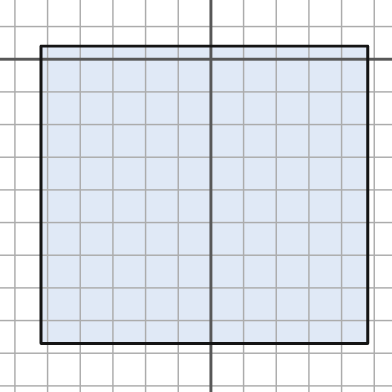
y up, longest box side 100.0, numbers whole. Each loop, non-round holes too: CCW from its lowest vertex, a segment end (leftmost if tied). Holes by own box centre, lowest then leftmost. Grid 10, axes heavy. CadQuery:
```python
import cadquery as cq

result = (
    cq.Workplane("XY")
    .moveTo(-52.0, -87.0)
    .lineTo(48.0, -87.0)
    .lineTo(48.0, 4.0)
    .lineTo(-52.0, 4.0)
    .close()
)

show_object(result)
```